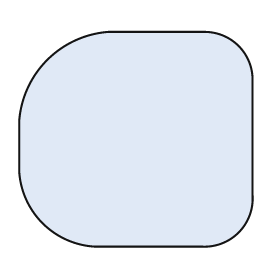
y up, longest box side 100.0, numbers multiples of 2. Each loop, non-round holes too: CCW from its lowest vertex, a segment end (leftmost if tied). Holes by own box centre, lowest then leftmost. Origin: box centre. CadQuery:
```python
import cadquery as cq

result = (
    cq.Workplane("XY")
    .moveTo(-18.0, -46.0)
    .lineTo(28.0, -46.0)
    .threePointArc((44.0, -40.0), (50.0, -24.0))
    .lineTo(50.0, 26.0)
    .threePointArc((44.0, 40.0), (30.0, 46.0))
    .lineTo(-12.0, 46.0)
    .threePointArc((-38.0, 34.0), (-50.0, 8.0))
    .lineTo(-50.0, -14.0)
    .threePointArc((-40.0, -36.0), (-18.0, -46.0))
    .close()
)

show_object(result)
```